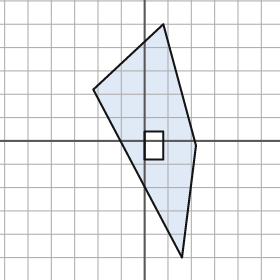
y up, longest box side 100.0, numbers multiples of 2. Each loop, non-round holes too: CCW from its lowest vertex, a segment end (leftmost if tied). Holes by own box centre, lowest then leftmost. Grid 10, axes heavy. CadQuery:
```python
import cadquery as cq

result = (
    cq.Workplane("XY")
    .moveTo(16.0, -50.0)
    .lineTo(22.0, -2.0)
    .lineTo(8.0, 50.0)
    .lineTo(-22.0, 22.0)
    .close()
    .moveTo(0.0, -8.0)
    .lineTo(8.0, -8.0)
    .lineTo(8.0, 4.0)
    .lineTo(0.0, 4.0)
    .close()
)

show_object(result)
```